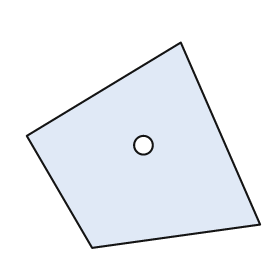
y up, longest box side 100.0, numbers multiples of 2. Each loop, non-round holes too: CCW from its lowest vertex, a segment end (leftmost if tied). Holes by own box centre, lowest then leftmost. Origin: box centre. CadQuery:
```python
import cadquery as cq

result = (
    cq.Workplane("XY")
    .moveTo(-22.0, -44.0)
    .lineTo(50.0, -34.0)
    .lineTo(16.0, 44.0)
    .lineTo(-50.0, 4.0)
    .close()
    .moveTo(0.0, 0.0)
    .circle(4.0)
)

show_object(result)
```